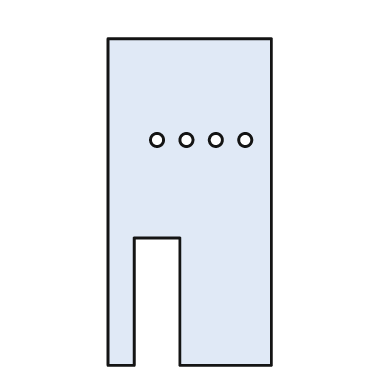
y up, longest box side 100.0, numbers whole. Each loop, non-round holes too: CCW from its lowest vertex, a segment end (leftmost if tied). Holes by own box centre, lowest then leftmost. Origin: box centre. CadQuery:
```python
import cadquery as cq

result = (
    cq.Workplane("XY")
    .moveTo(-25.0, -50.0)
    .lineTo(-17.0, -50.0)
    .lineTo(-17.0, -11.0)
    .lineTo(-3.0, -11.0)
    .lineTo(-3.0, -50.0)
    .lineTo(25.0, -50.0)
    .lineTo(25.0, 50.0)
    .lineTo(-25.0, 50.0)
    .close()
    .moveTo(-10.0, 19.0)
    .circle(2.0)
    .moveTo(-1.0, 19.0)
    .circle(2.0)
    .moveTo(8.0, 19.0)
    .circle(2.0)
    .moveTo(17.0, 19.0)
    .circle(2.0)
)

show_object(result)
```